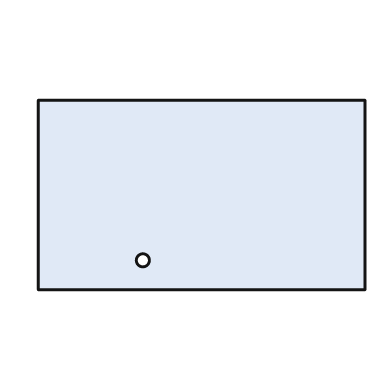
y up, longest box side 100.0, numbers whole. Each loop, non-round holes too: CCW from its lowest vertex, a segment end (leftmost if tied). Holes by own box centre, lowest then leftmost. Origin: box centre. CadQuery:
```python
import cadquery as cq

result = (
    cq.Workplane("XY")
    .moveTo(-50.0, -29.0)
    .lineTo(50.0, -29.0)
    .lineTo(50.0, 29.0)
    .lineTo(-50.0, 29.0)
    .close()
    .moveTo(-18.0, -20.0)
    .circle(2.0)
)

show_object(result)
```